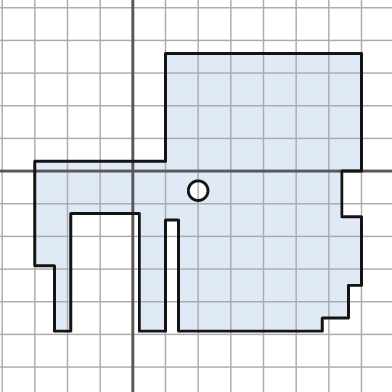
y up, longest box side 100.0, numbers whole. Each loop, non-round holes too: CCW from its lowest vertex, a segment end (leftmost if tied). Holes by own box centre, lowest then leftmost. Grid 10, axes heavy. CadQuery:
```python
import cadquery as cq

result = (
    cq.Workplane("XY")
    .moveTo(-24.0, -49.0)
    .lineTo(-19.0, -49.0)
    .lineTo(-19.0, -13.0)
    .lineTo(2.0, -13.0)
    .lineTo(2.0, -49.0)
    .lineTo(10.0, -49.0)
    .lineTo(10.0, -15.0)
    .lineTo(14.0, -15.0)
    .lineTo(14.0, -49.0)
    .lineTo(58.0, -49.0)
    .lineTo(58.0, -45.0)
    .lineTo(66.0, -45.0)
    .lineTo(66.0, -35.0)
    .lineTo(70.0, -35.0)
    .lineTo(70.0, -14.0)
    .lineTo(64.0, -14.0)
    .lineTo(64.0, 0.0)
    .lineTo(70.0, 0.0)
    .lineTo(70.0, 36.0)
    .lineTo(10.0, 36.0)
    .lineTo(10.0, 3.0)
    .lineTo(-30.0, 3.0)
    .lineTo(-30.0, -29.0)
    .lineTo(-24.0, -29.0)
    .close()
    .moveTo(20.0, -6.0)
    .circle(3.0)
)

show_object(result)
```